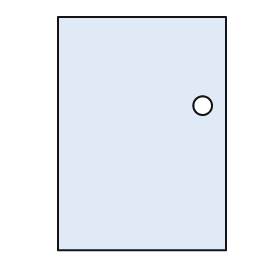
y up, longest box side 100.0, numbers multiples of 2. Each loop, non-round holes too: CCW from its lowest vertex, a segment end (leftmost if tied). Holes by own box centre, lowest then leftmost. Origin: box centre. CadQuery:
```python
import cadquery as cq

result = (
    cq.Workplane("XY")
    .moveTo(-36.0, -50.0)
    .lineTo(36.0, -50.0)
    .lineTo(36.0, 50.0)
    .lineTo(-36.0, 50.0)
    .close()
    .moveTo(26.0, 12.0)
    .circle(4.0)
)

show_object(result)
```